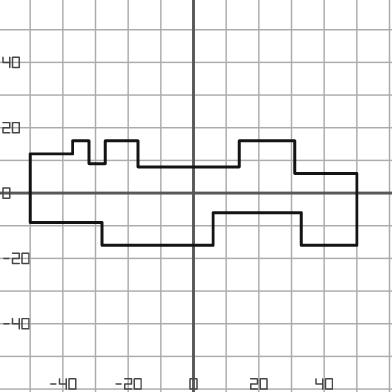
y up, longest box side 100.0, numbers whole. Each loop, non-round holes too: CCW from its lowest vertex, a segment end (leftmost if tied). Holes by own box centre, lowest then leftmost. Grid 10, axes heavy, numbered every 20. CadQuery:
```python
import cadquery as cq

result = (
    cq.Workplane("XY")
    .moveTo(-28.0, -16.0)
    .lineTo(6.0, -16.0)
    .lineTo(6.0, -6.0)
    .lineTo(33.0, -6.0)
    .lineTo(33.0, -16.0)
    .lineTo(50.0, -16.0)
    .lineTo(50.0, 6.0)
    .lineTo(31.0, 6.0)
    .lineTo(31.0, 16.0)
    .lineTo(14.0, 16.0)
    .lineTo(14.0, 8.0)
    .lineTo(-17.0, 8.0)
    .lineTo(-17.0, 16.0)
    .lineTo(-27.0, 16.0)
    .lineTo(-27.0, 9.0)
    .lineTo(-32.0, 9.0)
    .lineTo(-32.0, 16.0)
    .lineTo(-37.0, 16.0)
    .lineTo(-37.0, 12.0)
    .lineTo(-50.0, 12.0)
    .lineTo(-50.0, -9.0)
    .lineTo(-28.0, -9.0)
    .close()
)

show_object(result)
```